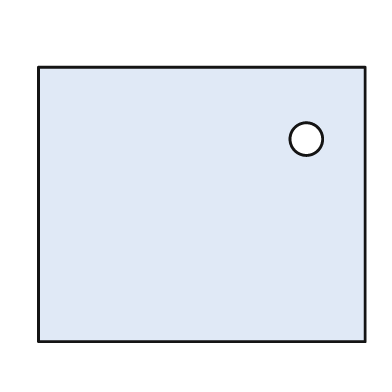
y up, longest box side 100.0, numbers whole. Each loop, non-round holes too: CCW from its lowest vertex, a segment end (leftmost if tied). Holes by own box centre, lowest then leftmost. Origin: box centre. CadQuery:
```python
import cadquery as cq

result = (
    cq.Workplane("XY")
    .moveTo(-50.0, -42.0)
    .lineTo(50.0, -42.0)
    .lineTo(50.0, 42.0)
    .lineTo(-50.0, 42.0)
    .close()
    .moveTo(32.0, 20.0)
    .circle(5.0)
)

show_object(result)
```